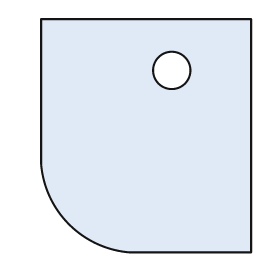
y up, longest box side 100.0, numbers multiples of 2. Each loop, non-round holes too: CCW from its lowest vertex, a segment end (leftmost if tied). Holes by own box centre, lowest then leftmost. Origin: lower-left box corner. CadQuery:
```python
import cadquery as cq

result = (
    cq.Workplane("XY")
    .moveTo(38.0, 0.0)
    .lineTo(90.0, 0.0)
    .lineTo(90.0, 100.0)
    .lineTo(0.0, 100.0)
    .lineTo(0.0, 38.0)
    .threePointArc((12.0, 12.0), (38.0, 0.0))
    .close()
    .moveTo(56.0, 78.0)
    .circle(8.0)
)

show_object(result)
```